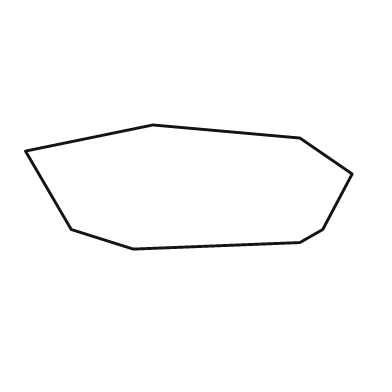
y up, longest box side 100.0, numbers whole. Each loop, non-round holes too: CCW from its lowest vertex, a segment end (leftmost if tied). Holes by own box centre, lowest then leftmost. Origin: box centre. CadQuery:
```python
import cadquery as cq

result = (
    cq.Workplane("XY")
    .moveTo(-17.0, -19.0)
    .lineTo(34.0, -17.0)
    .lineTo(41.0, -13.0)
    .lineTo(50.0, 4.0)
    .lineTo(34.0, 15.0)
    .lineTo(-11.0, 19.0)
    .lineTo(-50.0, 11.0)
    .lineTo(-36.0, -13.0)
    .close()
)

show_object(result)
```